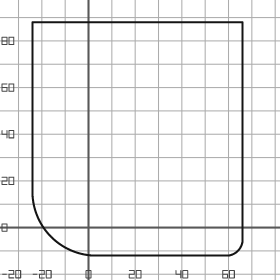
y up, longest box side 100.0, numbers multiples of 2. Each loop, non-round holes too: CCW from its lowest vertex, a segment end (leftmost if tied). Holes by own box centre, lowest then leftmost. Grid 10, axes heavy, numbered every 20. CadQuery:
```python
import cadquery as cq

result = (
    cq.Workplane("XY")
    .moveTo(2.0, -12.0)
    .lineTo(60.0, -12.0)
    .threePointArc((64.0, -10.0), (66.0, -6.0))
    .lineTo(66.0, 88.0)
    .lineTo(-24.0, 88.0)
    .lineTo(-24.0, 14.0)
    .threePointArc((-16.0, -4.0), (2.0, -12.0))
    .close()
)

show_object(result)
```